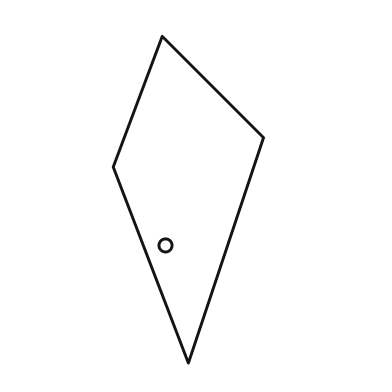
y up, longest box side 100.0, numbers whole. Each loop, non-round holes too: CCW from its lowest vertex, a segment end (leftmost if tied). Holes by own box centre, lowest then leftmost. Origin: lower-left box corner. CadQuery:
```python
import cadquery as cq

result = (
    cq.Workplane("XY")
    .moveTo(23.0, 0.0)
    .lineTo(46.0, 69.0)
    .lineTo(15.0, 100.0)
    .lineTo(0.0, 60.0)
    .close()
    .moveTo(16.0, 36.0)
    .circle(2.0)
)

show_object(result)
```